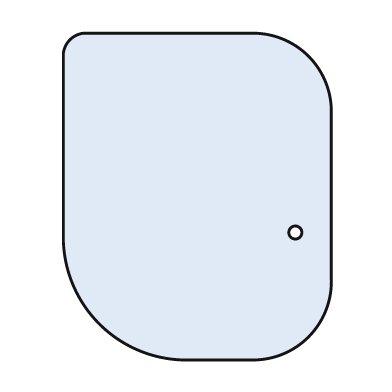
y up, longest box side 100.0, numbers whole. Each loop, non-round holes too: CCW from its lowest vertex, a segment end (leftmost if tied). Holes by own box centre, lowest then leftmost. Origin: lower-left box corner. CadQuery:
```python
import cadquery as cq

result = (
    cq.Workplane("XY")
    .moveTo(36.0, 0.0)
    .lineTo(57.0, 0.0)
    .threePointArc((75.0, 7.0), (82.0, 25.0))
    .lineTo(82.0, 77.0)
    .threePointArc((75.0, 93.0), (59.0, 100.0))
    .lineTo(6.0, 100.0)
    .threePointArc((2.0, 98.0), (0.0, 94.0))
    .lineTo(0.0, 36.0)
    .threePointArc((11.0, 11.0), (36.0, 0.0))
    .close()
    .moveTo(71.0, 39.0)
    .circle(2.0)
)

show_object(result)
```